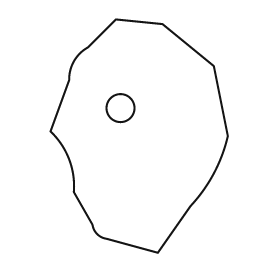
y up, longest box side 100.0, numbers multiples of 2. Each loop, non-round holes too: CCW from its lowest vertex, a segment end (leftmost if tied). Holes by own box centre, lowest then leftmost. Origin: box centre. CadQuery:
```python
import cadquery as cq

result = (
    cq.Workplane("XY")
    .moveTo(8.0, -50.0)
    .lineTo(22.0, -30.0)
    .threePointArc((32.0, -16.0), (38.0, 0.0))
    .lineTo(32.0, 30.0)
    .lineTo(10.0, 48.0)
    .lineTo(-10.0, 50.0)
    .lineTo(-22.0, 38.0)
    .threePointArc((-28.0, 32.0), (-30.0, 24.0))
    .lineTo(-38.0, 2.0)
    .threePointArc((-30.0, -10.0), (-28.0, -24.0))
    .lineTo(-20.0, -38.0)
    .threePointArc((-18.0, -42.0), (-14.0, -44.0))
    .close()
    .moveTo(-8.0, 12.0)
    .circle(6.0)
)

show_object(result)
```